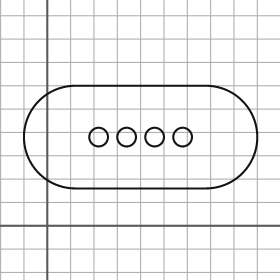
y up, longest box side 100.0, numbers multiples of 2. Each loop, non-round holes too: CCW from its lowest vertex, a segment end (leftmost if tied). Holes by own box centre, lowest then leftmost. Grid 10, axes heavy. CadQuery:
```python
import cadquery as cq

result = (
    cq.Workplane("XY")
    .moveTo(12.0, 16.0)
    .lineTo(68.0, 16.0)
    .threePointArc((90.0, 38.0), (68.0, 60.0))
    .lineTo(12.0, 60.0)
    .threePointArc((-10.0, 38.0), (12.0, 16.0))
    .close()
    .moveTo(22.0, 38.0)
    .circle(4.0)
    .moveTo(34.0, 38.0)
    .circle(4.0)
    .moveTo(46.0, 38.0)
    .circle(4.0)
    .moveTo(58.0, 38.0)
    .circle(4.0)
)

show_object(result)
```